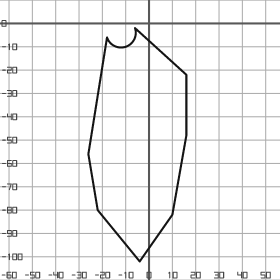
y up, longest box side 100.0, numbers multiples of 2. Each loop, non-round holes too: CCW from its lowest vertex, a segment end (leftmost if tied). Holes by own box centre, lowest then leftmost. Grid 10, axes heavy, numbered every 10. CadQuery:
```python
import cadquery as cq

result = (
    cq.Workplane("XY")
    .moveTo(-4.0, -102.0)
    .lineTo(10.0, -82.0)
    .lineTo(16.0, -48.0)
    .lineTo(16.0, -22.0)
    .lineTo(-6.0, -2.0)
    .threePointArc((-10.0, -10.0), (-18.0, -6.0))
    .lineTo(-26.0, -56.0)
    .lineTo(-22.0, -80.0)
    .close()
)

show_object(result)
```